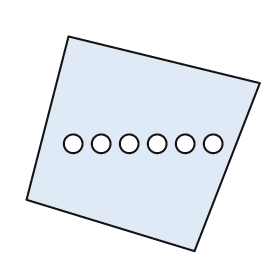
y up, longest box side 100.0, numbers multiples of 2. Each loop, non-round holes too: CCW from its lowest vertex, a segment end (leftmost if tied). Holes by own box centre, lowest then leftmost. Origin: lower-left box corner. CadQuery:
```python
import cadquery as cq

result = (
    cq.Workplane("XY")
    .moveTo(72.0, 0.0)
    .lineTo(100.0, 72.0)
    .lineTo(18.0, 92.0)
    .lineTo(0.0, 22.0)
    .close()
    .moveTo(20.0, 46.0)
    .circle(4.0)
    .moveTo(32.0, 46.0)
    .circle(4.0)
    .moveTo(44.0, 46.0)
    .circle(4.0)
    .moveTo(56.0, 46.0)
    .circle(4.0)
    .moveTo(68.0, 46.0)
    .circle(4.0)
    .moveTo(80.0, 46.0)
    .circle(4.0)
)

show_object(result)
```